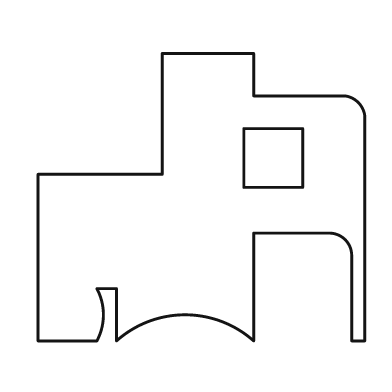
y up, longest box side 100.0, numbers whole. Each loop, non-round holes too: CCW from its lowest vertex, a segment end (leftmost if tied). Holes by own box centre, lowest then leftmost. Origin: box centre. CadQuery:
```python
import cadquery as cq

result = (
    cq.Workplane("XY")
    .moveTo(-50.0, -44.0)
    .lineTo(-32.0, -44.0)
    .threePointArc((-30.0, -36.0), (-32.0, -28.0))
    .lineTo(-26.0, -28.0)
    .lineTo(-26.0, -44.0)
    .threePointArc((-5.0, -36.0), (16.0, -44.0))
    .lineTo(16.0, -11.0)
    .lineTo(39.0, -11.0)
    .threePointArc((44.0, -13.0), (46.0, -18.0))
    .lineTo(46.0, -44.0)
    .lineTo(50.0, -44.0)
    .lineTo(50.0, 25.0)
    .threePointArc((48.0, 29.0), (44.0, 31.0))
    .lineTo(16.0, 31.0)
    .lineTo(16.0, 44.0)
    .lineTo(-12.0, 44.0)
    .lineTo(-12.0, 7.0)
    .lineTo(-50.0, 7.0)
    .close()
    .moveTo(13.0, 3.0)
    .lineTo(31.0, 3.0)
    .lineTo(31.0, 21.0)
    .lineTo(13.0, 21.0)
    .close()
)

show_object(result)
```